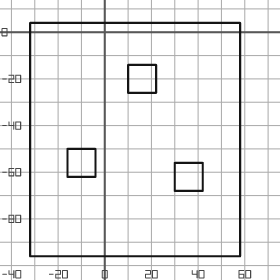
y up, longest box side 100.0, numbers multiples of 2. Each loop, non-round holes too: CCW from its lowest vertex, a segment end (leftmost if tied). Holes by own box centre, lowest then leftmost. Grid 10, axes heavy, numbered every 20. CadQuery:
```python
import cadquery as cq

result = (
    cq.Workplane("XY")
    .moveTo(-32.0, -96.0)
    .lineTo(58.0, -96.0)
    .lineTo(58.0, 4.0)
    .lineTo(-32.0, 4.0)
    .close()
    .moveTo(30.0, -68.0)
    .lineTo(42.0, -68.0)
    .lineTo(42.0, -56.0)
    .lineTo(30.0, -56.0)
    .close()
    .moveTo(-16.0, -62.0)
    .lineTo(-4.0, -62.0)
    .lineTo(-4.0, -50.0)
    .lineTo(-16.0, -50.0)
    .close()
    .moveTo(10.0, -26.0)
    .lineTo(22.0, -26.0)
    .lineTo(22.0, -14.0)
    .lineTo(10.0, -14.0)
    .close()
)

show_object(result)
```